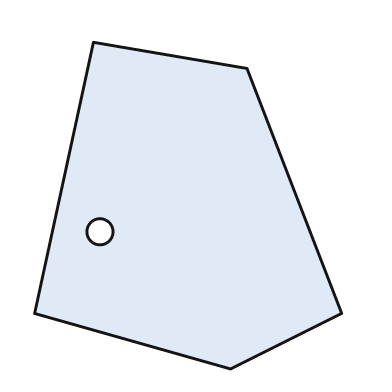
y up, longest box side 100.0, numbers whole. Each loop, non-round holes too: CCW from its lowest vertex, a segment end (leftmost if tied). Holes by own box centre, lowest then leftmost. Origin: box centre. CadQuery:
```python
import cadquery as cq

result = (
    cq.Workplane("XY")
    .moveTo(13.0, -50.0)
    .lineTo(47.0, -33.0)
    .lineTo(18.0, 42.0)
    .lineTo(-29.0, 50.0)
    .lineTo(-47.0, -33.0)
    .close()
    .moveTo(-27.0, -8.0)
    .circle(4.0)
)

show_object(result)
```